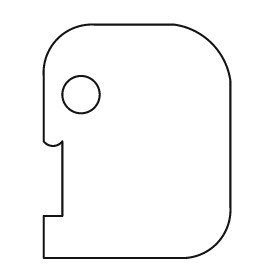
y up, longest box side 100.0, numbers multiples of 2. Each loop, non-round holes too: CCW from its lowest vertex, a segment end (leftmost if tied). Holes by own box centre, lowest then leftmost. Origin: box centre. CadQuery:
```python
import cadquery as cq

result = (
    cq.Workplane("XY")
    .moveTo(-40.0, -50.0)
    .lineTo(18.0, -50.0)
    .threePointArc((34.0, -44.0), (40.0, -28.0))
    .lineTo(40.0, 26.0)
    .threePointArc((32.0, 42.0), (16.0, 50.0))
    .lineTo(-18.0, 50.0)
    .threePointArc((-34.0, 44.0), (-40.0, 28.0))
    .lineTo(-40.0, 0.0)
    .threePointArc((-36.0, -2.0), (-32.0, 0.0))
    .lineTo(-32.0, -32.0)
    .lineTo(-40.0, -32.0)
    .close()
    .moveTo(-24.0, 20.0)
    .circle(8.0)
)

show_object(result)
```